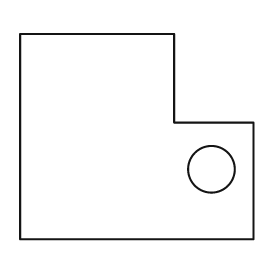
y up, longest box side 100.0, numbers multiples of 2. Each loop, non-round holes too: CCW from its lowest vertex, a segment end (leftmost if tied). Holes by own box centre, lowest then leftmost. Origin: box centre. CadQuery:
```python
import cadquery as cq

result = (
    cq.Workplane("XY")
    .moveTo(-50.0, -44.0)
    .lineTo(50.0, -44.0)
    .lineTo(50.0, 6.0)
    .lineTo(16.0, 6.0)
    .lineTo(16.0, 44.0)
    .lineTo(-50.0, 44.0)
    .close()
    .moveTo(32.0, -14.0)
    .circle(10.0)
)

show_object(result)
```